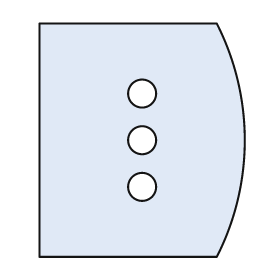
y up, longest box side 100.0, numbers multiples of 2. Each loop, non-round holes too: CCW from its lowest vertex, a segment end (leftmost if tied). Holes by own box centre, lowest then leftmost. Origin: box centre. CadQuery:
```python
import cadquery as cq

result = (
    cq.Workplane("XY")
    .moveTo(-44.0, -50.0)
    .lineTo(32.0, -50.0)
    .threePointArc((44.0, 0.0), (32.0, 50.0))
    .lineTo(-44.0, 50.0)
    .close()
    .moveTo(0.0, -20.0)
    .circle(6.0)
    .moveTo(0.0, 0.0)
    .circle(6.0)
    .moveTo(0.0, 20.0)
    .circle(6.0)
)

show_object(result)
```